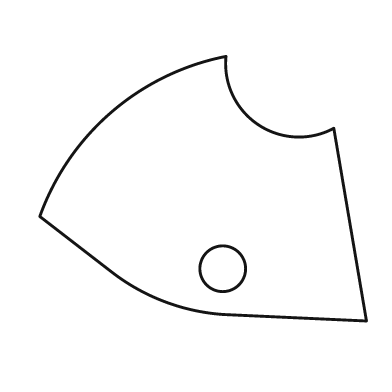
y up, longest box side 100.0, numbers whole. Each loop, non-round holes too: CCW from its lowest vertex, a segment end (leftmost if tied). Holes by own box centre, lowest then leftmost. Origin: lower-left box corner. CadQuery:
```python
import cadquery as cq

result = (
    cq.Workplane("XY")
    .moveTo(100.0, 0.0)
    .lineTo(90.0, 59.0)
    .threePointArc((67.0, 60.0), (57.0, 81.0))
    .threePointArc((22.0, 64.0), (0.0, 32.0))
    .lineTo(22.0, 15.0)
    .threePointArc((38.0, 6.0), (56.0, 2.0))
    .close()
    .moveTo(56.0, 16.0)
    .circle(7.0)
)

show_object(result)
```